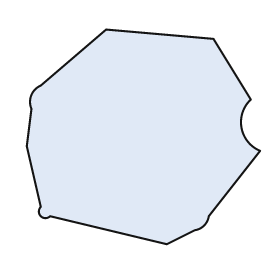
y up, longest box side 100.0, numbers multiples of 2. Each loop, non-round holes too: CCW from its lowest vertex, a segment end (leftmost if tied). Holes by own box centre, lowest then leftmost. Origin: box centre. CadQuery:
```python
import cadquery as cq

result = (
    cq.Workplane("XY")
    .moveTo(10.0, -46.0)
    .lineTo(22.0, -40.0)
    .threePointArc((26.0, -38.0), (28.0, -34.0))
    .lineTo(50.0, -6.0)
    .threePointArc((42.0, 4.0), (46.0, 16.0))
    .lineTo(30.0, 42.0)
    .lineTo(-16.0, 46.0)
    .lineTo(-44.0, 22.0)
    .threePointArc((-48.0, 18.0), (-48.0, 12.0))
    .lineTo(-50.0, -4.0)
    .lineTo(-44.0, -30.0)
    .threePointArc((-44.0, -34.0), (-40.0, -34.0))
    .close()
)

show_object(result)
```